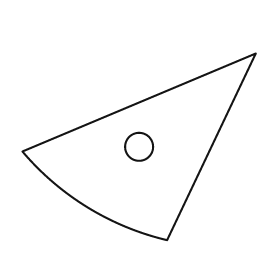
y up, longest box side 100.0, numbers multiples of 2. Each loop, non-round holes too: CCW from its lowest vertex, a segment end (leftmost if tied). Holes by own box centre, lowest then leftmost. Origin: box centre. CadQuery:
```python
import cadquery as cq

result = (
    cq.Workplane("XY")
    .moveTo(12.0, -40.0)
    .lineTo(50.0, 40.0)
    .lineTo(-50.0, -2.0)
    .threePointArc((-22.0, -26.0), (12.0, -40.0))
    .close()
    .moveTo(0.0, 0.0)
    .circle(6.0)
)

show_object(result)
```